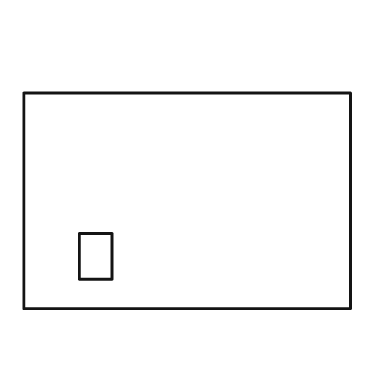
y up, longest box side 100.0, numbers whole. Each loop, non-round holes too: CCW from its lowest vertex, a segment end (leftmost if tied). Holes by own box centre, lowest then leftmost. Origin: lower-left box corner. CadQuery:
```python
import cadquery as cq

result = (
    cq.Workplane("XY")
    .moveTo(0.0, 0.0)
    .lineTo(100.0, 0.0)
    .lineTo(100.0, 66.0)
    .lineTo(0.0, 66.0)
    .close()
    .moveTo(17.0, 9.0)
    .lineTo(27.0, 9.0)
    .lineTo(27.0, 23.0)
    .lineTo(17.0, 23.0)
    .close()
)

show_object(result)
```